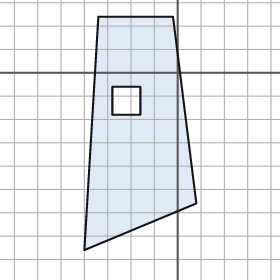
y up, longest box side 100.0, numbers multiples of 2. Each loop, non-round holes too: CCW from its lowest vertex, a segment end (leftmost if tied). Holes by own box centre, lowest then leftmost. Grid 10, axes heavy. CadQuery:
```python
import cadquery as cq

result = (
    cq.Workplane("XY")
    .moveTo(-40.0, -76.0)
    .lineTo(8.0, -56.0)
    .lineTo(-2.0, 24.0)
    .lineTo(-34.0, 24.0)
    .close()
    .moveTo(-28.0, -18.0)
    .lineTo(-16.0, -18.0)
    .lineTo(-16.0, -6.0)
    .lineTo(-28.0, -6.0)
    .close()
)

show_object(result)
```